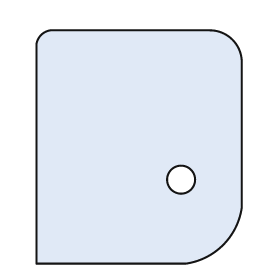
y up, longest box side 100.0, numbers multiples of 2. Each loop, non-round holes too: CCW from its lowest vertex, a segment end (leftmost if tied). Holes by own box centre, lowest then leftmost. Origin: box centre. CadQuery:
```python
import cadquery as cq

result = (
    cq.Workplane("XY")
    .moveTo(-44.0, -50.0)
    .lineTo(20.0, -50.0)
    .threePointArc((36.0, -42.0), (44.0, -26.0))
    .lineTo(44.0, 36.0)
    .threePointArc((40.0, 46.0), (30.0, 50.0))
    .lineTo(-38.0, 50.0)
    .threePointArc((-42.0, 48.0), (-44.0, 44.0))
    .close()
    .moveTo(18.0, -14.0)
    .circle(6.0)
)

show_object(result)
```